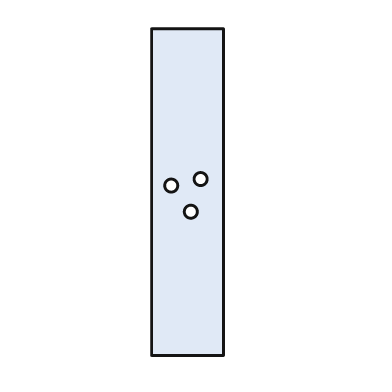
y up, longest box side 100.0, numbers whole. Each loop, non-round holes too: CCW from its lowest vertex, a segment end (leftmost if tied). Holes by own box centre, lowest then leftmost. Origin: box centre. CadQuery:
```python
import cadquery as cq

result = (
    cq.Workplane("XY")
    .moveTo(-11.0, -50.0)
    .lineTo(11.0, -50.0)
    .lineTo(11.0, 50.0)
    .lineTo(-11.0, 50.0)
    .close()
    .moveTo(1.0, -6.0)
    .circle(2.0)
    .moveTo(-5.0, 2.0)
    .circle(2.0)
    .moveTo(4.0, 4.0)
    .circle(2.0)
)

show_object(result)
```